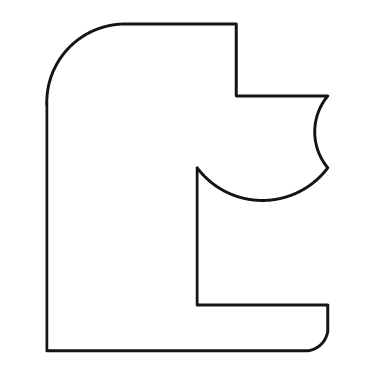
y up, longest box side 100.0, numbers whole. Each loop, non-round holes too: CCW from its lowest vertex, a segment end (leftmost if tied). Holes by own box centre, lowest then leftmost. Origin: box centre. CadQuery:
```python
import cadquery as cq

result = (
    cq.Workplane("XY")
    .moveTo(-43.0, -50.0)
    .lineTo(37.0, -50.0)
    .threePointArc((41.0, -48.0), (43.0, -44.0))
    .lineTo(43.0, -36.0)
    .lineTo(3.0, -36.0)
    .lineTo(3.0, 6.0)
    .threePointArc((23.0, -4.0), (43.0, 6.0))
    .threePointArc((39.0, 17.0), (43.0, 28.0))
    .lineTo(15.0, 28.0)
    .lineTo(15.0, 50.0)
    .lineTo(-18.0, 50.0)
    .threePointArc((-36.0, 43.0), (-43.0, 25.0))
    .close()
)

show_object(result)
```